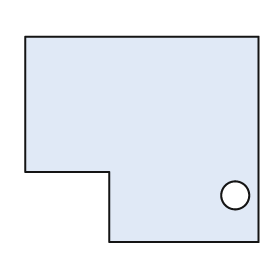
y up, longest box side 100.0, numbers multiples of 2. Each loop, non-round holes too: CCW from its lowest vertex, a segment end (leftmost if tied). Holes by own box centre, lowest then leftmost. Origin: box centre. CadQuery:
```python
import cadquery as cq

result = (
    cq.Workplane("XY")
    .moveTo(-14.0, -44.0)
    .lineTo(50.0, -44.0)
    .lineTo(50.0, 44.0)
    .lineTo(-50.0, 44.0)
    .lineTo(-50.0, -14.0)
    .lineTo(-14.0, -14.0)
    .close()
    .moveTo(40.0, -24.0)
    .circle(6.0)
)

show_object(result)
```